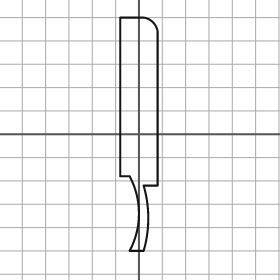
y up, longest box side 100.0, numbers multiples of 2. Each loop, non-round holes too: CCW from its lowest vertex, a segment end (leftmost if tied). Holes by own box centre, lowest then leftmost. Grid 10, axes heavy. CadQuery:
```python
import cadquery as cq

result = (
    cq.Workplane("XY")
    .moveTo(-4.0, -50.0)
    .lineTo(2.0, -50.0)
    .threePointArc((4.0, -36.0), (2.0, -22.0))
    .lineTo(8.0, -22.0)
    .lineTo(8.0, 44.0)
    .threePointArc((6.0, 48.0), (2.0, 50.0))
    .lineTo(-8.0, 50.0)
    .lineTo(-8.0, -18.0)
    .lineTo(-4.0, -18.0)
    .threePointArc((0.0, -34.0), (-4.0, -50.0))
    .close()
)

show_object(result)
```